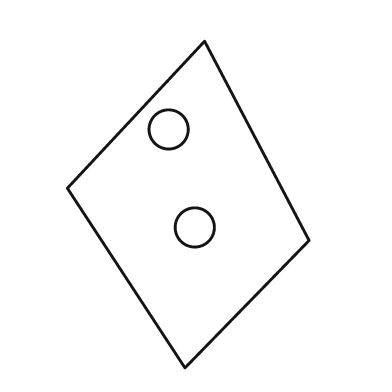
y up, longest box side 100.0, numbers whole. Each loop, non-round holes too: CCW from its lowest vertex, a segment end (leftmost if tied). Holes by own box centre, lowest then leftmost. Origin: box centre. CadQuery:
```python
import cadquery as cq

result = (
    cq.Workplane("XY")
    .moveTo(-1.0, -50.0)
    .lineTo(37.0, -11.0)
    .lineTo(5.0, 50.0)
    .lineTo(-37.0, 5.0)
    .close()
    .moveTo(2.0, -7.0)
    .circle(6.0)
    .moveTo(-6.0, 23.0)
    .circle(6.0)
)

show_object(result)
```